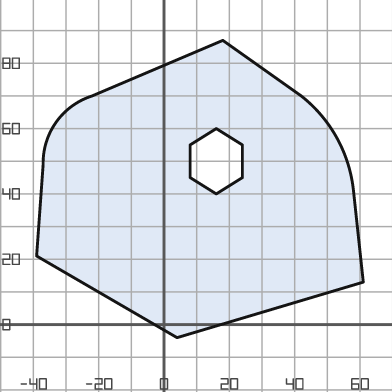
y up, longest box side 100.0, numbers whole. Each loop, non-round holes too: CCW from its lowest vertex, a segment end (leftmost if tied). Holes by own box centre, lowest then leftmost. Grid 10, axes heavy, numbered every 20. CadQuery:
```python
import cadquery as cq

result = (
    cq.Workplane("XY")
    .moveTo(4.0, -4.0)
    .lineTo(61.0, 13.0)
    .lineTo(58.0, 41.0)
    .threePointArc((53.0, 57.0), (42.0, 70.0))
    .lineTo(18.0, 87.0)
    .lineTo(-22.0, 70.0)
    .threePointArc((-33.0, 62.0), (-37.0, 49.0))
    .lineTo(-39.0, 21.0)
    .close()
    .moveTo(16.0, 40.0)
    .lineTo(24.0, 45.0)
    .lineTo(24.0, 55.0)
    .lineTo(16.0, 60.0)
    .lineTo(8.0, 55.0)
    .lineTo(8.0, 45.0)
    .close()
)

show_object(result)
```